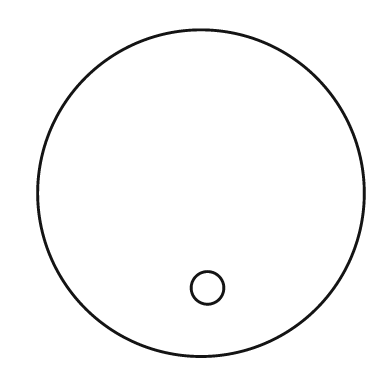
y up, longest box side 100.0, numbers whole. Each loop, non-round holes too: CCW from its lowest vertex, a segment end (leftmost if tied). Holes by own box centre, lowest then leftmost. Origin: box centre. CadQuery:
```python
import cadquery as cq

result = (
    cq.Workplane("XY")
    .moveTo(0.0, 0.0)
    .circle(50.0)
    .moveTo(2.0, -29.0)
    .circle(5.0)
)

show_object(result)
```